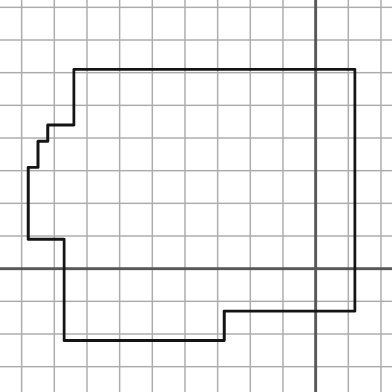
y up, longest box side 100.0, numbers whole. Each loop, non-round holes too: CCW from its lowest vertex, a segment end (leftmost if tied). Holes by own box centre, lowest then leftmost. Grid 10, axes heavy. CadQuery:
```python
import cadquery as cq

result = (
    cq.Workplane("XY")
    .moveTo(-77.0, -22.0)
    .lineTo(-28.0, -22.0)
    .lineTo(-28.0, -13.0)
    .lineTo(12.0, -13.0)
    .lineTo(12.0, 61.0)
    .lineTo(-74.0, 61.0)
    .lineTo(-74.0, 44.0)
    .lineTo(-82.0, 44.0)
    .lineTo(-82.0, 39.0)
    .lineTo(-85.0, 39.0)
    .lineTo(-85.0, 31.0)
    .lineTo(-88.0, 31.0)
    .lineTo(-88.0, 9.0)
    .lineTo(-77.0, 9.0)
    .close()
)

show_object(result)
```